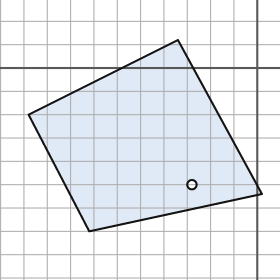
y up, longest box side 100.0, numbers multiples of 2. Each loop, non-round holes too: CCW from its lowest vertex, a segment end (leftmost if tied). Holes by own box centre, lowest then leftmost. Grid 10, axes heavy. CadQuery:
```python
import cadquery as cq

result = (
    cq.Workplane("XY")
    .moveTo(-72.0, -70.0)
    .lineTo(2.0, -54.0)
    .lineTo(-34.0, 12.0)
    .lineTo(-98.0, -20.0)
    .close()
    .moveTo(-28.0, -50.0)
    .circle(2.0)
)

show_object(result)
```